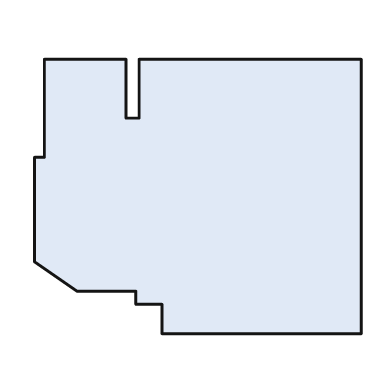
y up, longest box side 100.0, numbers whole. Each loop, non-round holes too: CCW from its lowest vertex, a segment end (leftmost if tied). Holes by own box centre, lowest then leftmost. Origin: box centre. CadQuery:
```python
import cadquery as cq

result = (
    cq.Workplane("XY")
    .moveTo(-11.0, -42.0)
    .lineTo(50.0, -42.0)
    .lineTo(50.0, 42.0)
    .lineTo(-18.0, 42.0)
    .lineTo(-18.0, 24.0)
    .lineTo(-22.0, 24.0)
    .lineTo(-22.0, 42.0)
    .lineTo(-47.0, 42.0)
    .lineTo(-47.0, 12.0)
    .lineTo(-50.0, 12.0)
    .lineTo(-50.0, -20.0)
    .lineTo(-37.0, -29.0)
    .lineTo(-19.0, -29.0)
    .lineTo(-19.0, -33.0)
    .lineTo(-11.0, -33.0)
    .close()
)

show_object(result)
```